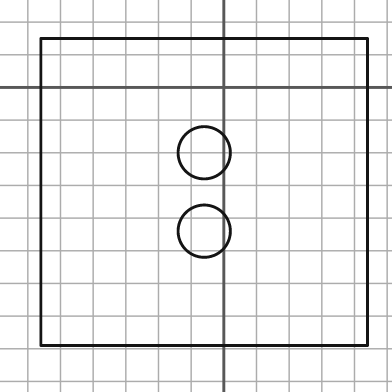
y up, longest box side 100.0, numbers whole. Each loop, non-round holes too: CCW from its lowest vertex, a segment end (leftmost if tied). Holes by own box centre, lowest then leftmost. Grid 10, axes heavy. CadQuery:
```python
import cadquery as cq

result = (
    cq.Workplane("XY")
    .moveTo(-56.0, -79.0)
    .lineTo(44.0, -79.0)
    .lineTo(44.0, 15.0)
    .lineTo(-56.0, 15.0)
    .close()
    .moveTo(-6.0, -44.0)
    .circle(8.0)
    .moveTo(-6.0, -20.0)
    .circle(8.0)
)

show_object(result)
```